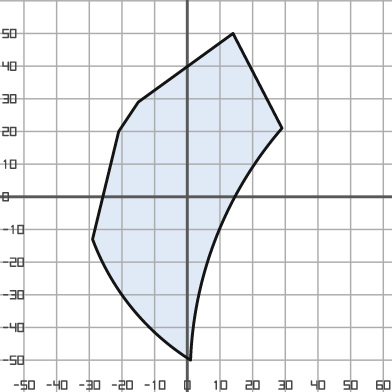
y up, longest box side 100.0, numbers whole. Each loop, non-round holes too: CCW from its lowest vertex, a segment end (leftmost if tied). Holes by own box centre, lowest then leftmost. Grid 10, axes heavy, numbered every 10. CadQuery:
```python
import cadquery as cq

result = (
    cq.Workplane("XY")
    .moveTo(1.0, -50.0)
    .threePointArc((9.0, -12.0), (29.0, 21.0))
    .lineTo(14.0, 50.0)
    .lineTo(-15.0, 29.0)
    .lineTo(-21.0, 20.0)
    .lineTo(-29.0, -13.0)
    .threePointArc((-17.0, -34.0), (1.0, -50.0))
    .close()
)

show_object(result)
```